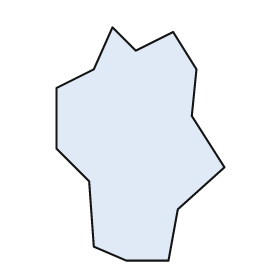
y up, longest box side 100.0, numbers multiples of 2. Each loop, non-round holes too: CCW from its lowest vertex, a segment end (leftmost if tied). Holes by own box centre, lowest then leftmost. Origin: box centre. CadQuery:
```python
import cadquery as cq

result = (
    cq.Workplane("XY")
    .moveTo(-6.0, -50.0)
    .lineTo(12.0, -50.0)
    .lineTo(16.0, -28.0)
    .lineTo(36.0, -10.0)
    .lineTo(22.0, 12.0)
    .lineTo(24.0, 32.0)
    .lineTo(14.0, 48.0)
    .lineTo(-2.0, 40.0)
    .lineTo(-12.0, 50.0)
    .lineTo(-20.0, 32.0)
    .lineTo(-36.0, 24.0)
    .lineTo(-36.0, -2.0)
    .lineTo(-22.0, -16.0)
    .lineTo(-20.0, -44.0)
    .close()
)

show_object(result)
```